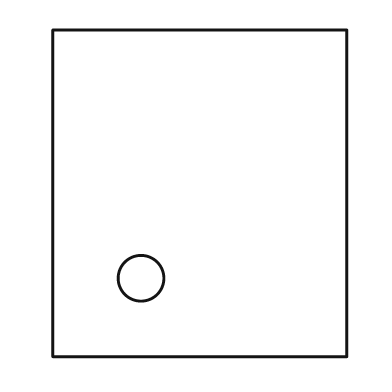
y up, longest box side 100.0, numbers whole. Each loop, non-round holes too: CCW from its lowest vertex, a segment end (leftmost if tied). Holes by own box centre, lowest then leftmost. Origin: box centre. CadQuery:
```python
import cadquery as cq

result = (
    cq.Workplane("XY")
    .moveTo(-45.0, -50.0)
    .lineTo(45.0, -50.0)
    .lineTo(45.0, 50.0)
    .lineTo(-45.0, 50.0)
    .close()
    .moveTo(-18.0, -26.0)
    .circle(7.0)
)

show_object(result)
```